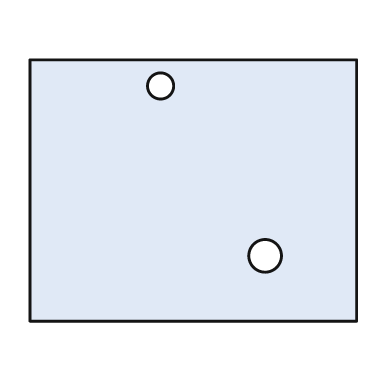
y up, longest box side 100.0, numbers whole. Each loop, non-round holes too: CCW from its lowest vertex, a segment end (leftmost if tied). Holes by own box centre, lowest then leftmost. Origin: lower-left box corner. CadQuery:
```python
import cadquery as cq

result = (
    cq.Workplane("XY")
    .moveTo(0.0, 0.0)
    .lineTo(100.0, 0.0)
    .lineTo(100.0, 80.0)
    .lineTo(0.0, 80.0)
    .close()
    .moveTo(72.0, 20.0)
    .circle(5.0)
    .moveTo(40.0, 72.0)
    .circle(4.0)
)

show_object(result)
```